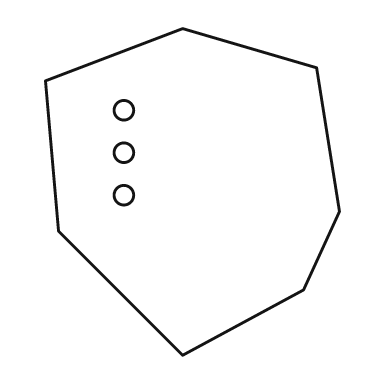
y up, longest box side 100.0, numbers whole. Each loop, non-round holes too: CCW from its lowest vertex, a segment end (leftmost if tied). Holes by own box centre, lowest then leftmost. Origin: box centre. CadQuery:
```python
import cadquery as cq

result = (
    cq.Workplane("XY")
    .moveTo(-3.0, -50.0)
    .lineTo(34.0, -30.0)
    .lineTo(45.0, -6.0)
    .lineTo(38.0, 38.0)
    .lineTo(-3.0, 50.0)
    .lineTo(-45.0, 34.0)
    .lineTo(-41.0, -12.0)
    .close()
    .moveTo(-21.0, -1.0)
    .circle(3.0)
    .moveTo(-21.0, 12.0)
    .circle(3.0)
    .moveTo(-21.0, 25.0)
    .circle(3.0)
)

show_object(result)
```